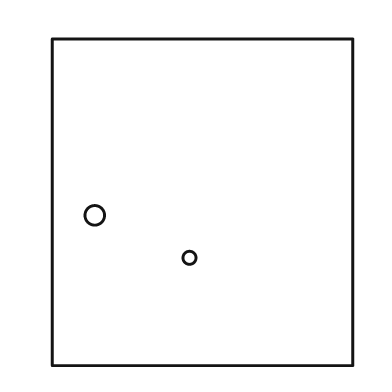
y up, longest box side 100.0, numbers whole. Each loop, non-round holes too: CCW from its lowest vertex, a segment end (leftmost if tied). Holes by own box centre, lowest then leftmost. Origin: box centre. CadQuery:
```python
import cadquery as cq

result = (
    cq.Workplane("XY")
    .moveTo(-46.0, -50.0)
    .lineTo(46.0, -50.0)
    .lineTo(46.0, 50.0)
    .lineTo(-46.0, 50.0)
    .close()
    .moveTo(-4.0, -17.0)
    .circle(2.0)
    .moveTo(-33.0, -4.0)
    .circle(3.0)
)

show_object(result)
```